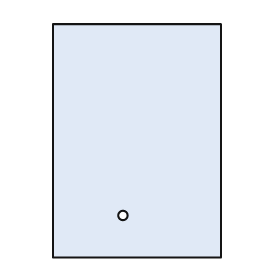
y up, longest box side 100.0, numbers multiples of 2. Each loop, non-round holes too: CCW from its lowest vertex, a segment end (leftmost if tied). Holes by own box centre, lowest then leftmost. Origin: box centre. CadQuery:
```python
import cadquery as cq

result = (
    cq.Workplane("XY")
    .moveTo(-36.0, -50.0)
    .lineTo(36.0, -50.0)
    .lineTo(36.0, 50.0)
    .lineTo(-36.0, 50.0)
    .close()
    .moveTo(-6.0, -32.0)
    .circle(2.0)
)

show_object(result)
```